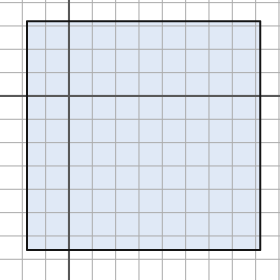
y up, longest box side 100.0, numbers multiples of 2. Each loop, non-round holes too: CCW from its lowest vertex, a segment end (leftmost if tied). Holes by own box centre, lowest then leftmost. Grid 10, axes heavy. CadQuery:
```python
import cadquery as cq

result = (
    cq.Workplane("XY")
    .moveTo(-18.0, -66.0)
    .lineTo(82.0, -66.0)
    .lineTo(82.0, 32.0)
    .lineTo(-18.0, 32.0)
    .close()
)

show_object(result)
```